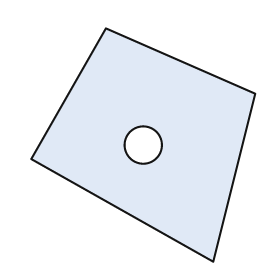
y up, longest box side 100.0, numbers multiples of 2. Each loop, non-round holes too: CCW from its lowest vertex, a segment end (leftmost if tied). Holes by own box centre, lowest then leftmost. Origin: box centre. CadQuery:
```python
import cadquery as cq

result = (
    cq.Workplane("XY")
    .moveTo(30.0, -50.0)
    .lineTo(48.0, 22.0)
    .lineTo(-16.0, 50.0)
    .lineTo(-48.0, -6.0)
    .close()
    .moveTo(0.0, 0.0)
    .circle(8.0)
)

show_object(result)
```